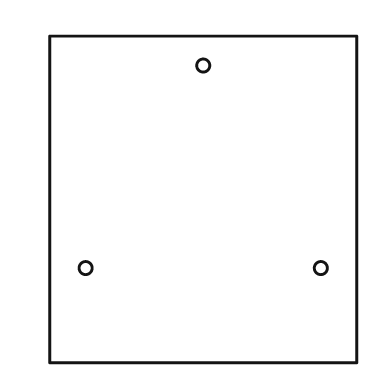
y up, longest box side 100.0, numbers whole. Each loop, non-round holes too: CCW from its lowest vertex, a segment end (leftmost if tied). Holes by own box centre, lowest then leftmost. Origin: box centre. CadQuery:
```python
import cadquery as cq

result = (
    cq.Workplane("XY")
    .moveTo(-47.0, -50.0)
    .lineTo(47.0, -50.0)
    .lineTo(47.0, 50.0)
    .lineTo(-47.0, 50.0)
    .close()
    .moveTo(-36.0, -21.0)
    .circle(2.0)
    .moveTo(36.0, -21.0)
    .circle(2.0)
    .moveTo(0.0, 41.0)
    .circle(2.0)
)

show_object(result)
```